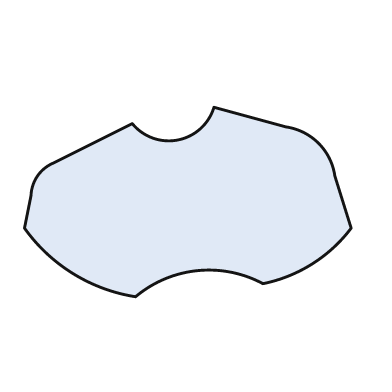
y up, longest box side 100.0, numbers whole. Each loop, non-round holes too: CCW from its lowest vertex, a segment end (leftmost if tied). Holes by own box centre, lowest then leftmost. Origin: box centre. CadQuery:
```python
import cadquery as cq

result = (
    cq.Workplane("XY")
    .moveTo(-16.0, -29.0)
    .threePointArc((3.0, -21.0), (23.0, -25.0))
    .threePointArc((38.0, -19.0), (50.0, -8.0))
    .lineTo(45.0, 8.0)
    .threePointArc((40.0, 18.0), (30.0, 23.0))
    .lineTo(8.0, 29.0)
    .threePointArc((-3.0, 19.0), (-17.0, 24.0))
    .lineTo(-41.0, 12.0)
    .threePointArc((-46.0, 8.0), (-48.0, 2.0))
    .lineTo(-50.0, -8.0)
    .threePointArc((-35.0, -22.0), (-16.0, -29.0))
    .close()
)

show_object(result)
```